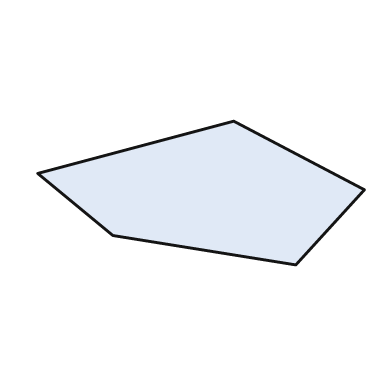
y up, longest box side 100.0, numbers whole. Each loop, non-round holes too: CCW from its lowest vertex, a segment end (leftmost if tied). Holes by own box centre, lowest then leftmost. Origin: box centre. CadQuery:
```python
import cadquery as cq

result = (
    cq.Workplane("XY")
    .moveTo(29.0, -22.0)
    .lineTo(50.0, 1.0)
    .lineTo(10.0, 22.0)
    .lineTo(-50.0, 6.0)
    .lineTo(-27.0, -13.0)
    .close()
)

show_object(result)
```